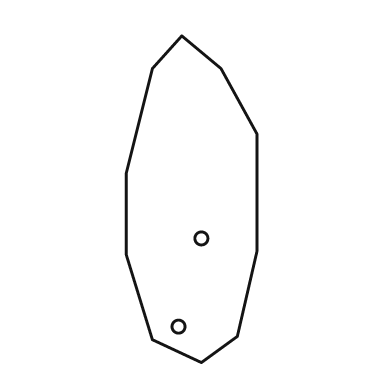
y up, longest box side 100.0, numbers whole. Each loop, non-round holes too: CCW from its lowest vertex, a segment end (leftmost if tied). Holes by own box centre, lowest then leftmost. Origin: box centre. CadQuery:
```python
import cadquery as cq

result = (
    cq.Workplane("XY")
    .moveTo(3.0, -50.0)
    .lineTo(14.0, -42.0)
    .lineTo(20.0, -16.0)
    .lineTo(20.0, 20.0)
    .lineTo(9.0, 40.0)
    .lineTo(-3.0, 50.0)
    .lineTo(-12.0, 40.0)
    .lineTo(-20.0, 8.0)
    .lineTo(-20.0, -17.0)
    .lineTo(-12.0, -43.0)
    .close()
    .moveTo(-4.0, -39.0)
    .circle(2.0)
    .moveTo(3.0, -12.0)
    .circle(2.0)
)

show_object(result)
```